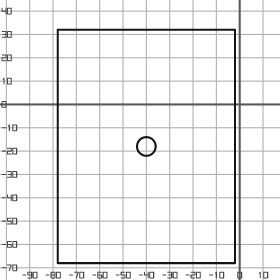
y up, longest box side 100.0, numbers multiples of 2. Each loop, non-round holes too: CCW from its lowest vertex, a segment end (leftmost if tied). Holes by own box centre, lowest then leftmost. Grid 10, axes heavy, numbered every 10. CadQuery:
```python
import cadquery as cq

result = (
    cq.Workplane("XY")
    .moveTo(-78.0, -68.0)
    .lineTo(-2.0, -68.0)
    .lineTo(-2.0, 32.0)
    .lineTo(-78.0, 32.0)
    .close()
    .moveTo(-40.0, -18.0)
    .circle(4.0)
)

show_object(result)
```